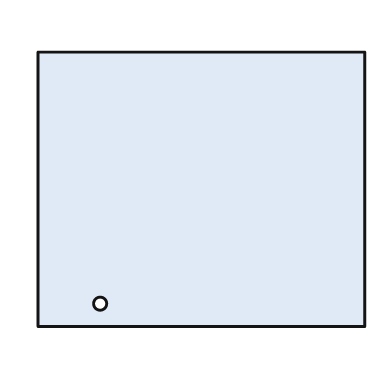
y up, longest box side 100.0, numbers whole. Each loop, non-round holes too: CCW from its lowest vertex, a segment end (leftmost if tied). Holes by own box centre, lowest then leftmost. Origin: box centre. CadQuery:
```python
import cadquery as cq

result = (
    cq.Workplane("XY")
    .moveTo(-50.0, -42.0)
    .lineTo(50.0, -42.0)
    .lineTo(50.0, 42.0)
    .lineTo(-50.0, 42.0)
    .close()
    .moveTo(-31.0, -35.0)
    .circle(2.0)
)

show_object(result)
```